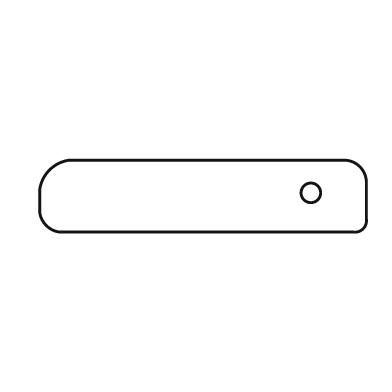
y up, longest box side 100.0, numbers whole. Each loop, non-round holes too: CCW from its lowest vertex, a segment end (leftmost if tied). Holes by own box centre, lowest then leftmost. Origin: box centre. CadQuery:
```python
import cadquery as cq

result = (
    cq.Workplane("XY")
    .moveTo(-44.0, -11.0)
    .lineTo(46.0, -11.0)
    .threePointArc((49.0, -10.0), (50.0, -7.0))
    .lineTo(50.0, 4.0)
    .threePointArc((48.0, 9.0), (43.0, 11.0))
    .lineTo(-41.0, 11.0)
    .threePointArc((-47.0, 8.0), (-50.0, 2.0))
    .lineTo(-50.0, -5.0)
    .threePointArc((-48.0, -9.0), (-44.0, -11.0))
    .close()
    .moveTo(33.0, 1.0)
    .circle(3.0)
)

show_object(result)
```